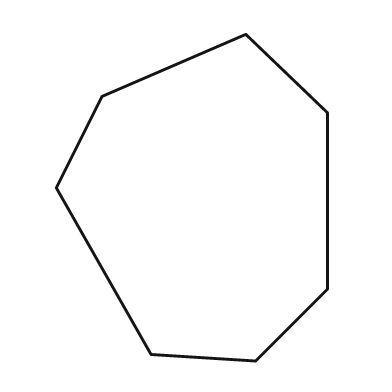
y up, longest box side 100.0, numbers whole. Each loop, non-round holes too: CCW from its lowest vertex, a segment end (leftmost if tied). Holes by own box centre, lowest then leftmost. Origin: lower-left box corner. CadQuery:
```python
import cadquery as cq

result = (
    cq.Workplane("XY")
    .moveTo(61.0, 0.0)
    .lineTo(83.0, 22.0)
    .lineTo(83.0, 76.0)
    .lineTo(58.0, 100.0)
    .lineTo(14.0, 81.0)
    .lineTo(0.0, 53.0)
    .lineTo(29.0, 2.0)
    .close()
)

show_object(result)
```